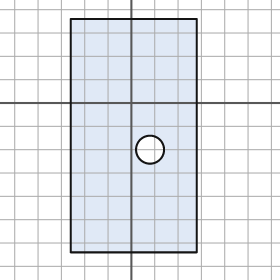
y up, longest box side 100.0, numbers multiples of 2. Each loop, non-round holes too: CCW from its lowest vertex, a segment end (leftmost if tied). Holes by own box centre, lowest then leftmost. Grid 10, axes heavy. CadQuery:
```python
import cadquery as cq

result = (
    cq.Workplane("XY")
    .moveTo(-26.0, -64.0)
    .lineTo(28.0, -64.0)
    .lineTo(28.0, 36.0)
    .lineTo(-26.0, 36.0)
    .close()
    .moveTo(8.0, -20.0)
    .circle(6.0)
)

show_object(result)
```